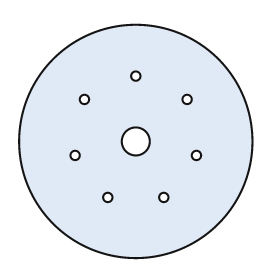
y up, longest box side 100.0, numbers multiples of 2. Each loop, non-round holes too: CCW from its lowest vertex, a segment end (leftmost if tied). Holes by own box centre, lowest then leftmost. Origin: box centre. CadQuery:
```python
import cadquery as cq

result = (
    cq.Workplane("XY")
    .moveTo(0.0, 0.0)
    .circle(50.0)
    .moveTo(-12.0, -24.0)
    .circle(2.0)
    .moveTo(12.0, -24.0)
    .circle(2.0)
    .moveTo(-26.0, -6.0)
    .circle(2.0)
    .moveTo(26.0, -6.0)
    .circle(2.0)
    .moveTo(0.0, 0.0)
    .circle(6.0)
    .moveTo(-22.0, 18.0)
    .circle(2.0)
    .moveTo(22.0, 18.0)
    .circle(2.0)
    .moveTo(0.0, 28.0)
    .circle(2.0)
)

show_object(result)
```